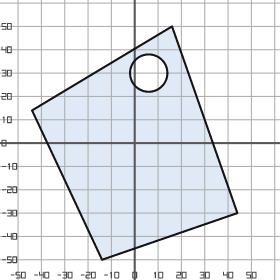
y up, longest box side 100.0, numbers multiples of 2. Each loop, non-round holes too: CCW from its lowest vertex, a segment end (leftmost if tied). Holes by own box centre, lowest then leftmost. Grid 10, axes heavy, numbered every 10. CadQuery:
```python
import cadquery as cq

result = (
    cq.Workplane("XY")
    .moveTo(-14.0, -50.0)
    .lineTo(44.0, -30.0)
    .lineTo(16.0, 50.0)
    .lineTo(-44.0, 14.0)
    .close()
    .moveTo(6.0, 30.0)
    .circle(8.0)
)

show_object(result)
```